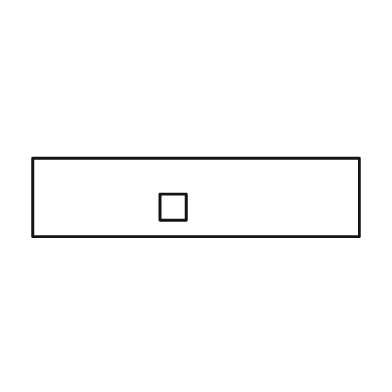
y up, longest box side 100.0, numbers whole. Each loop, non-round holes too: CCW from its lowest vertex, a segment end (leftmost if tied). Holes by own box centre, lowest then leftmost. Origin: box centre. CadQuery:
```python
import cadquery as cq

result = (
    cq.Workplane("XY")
    .moveTo(-50.0, -12.0)
    .lineTo(50.0, -12.0)
    .lineTo(50.0, 12.0)
    .lineTo(-50.0, 12.0)
    .close()
    .moveTo(-11.0, -7.0)
    .lineTo(-3.0, -7.0)
    .lineTo(-3.0, 1.0)
    .lineTo(-11.0, 1.0)
    .close()
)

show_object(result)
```